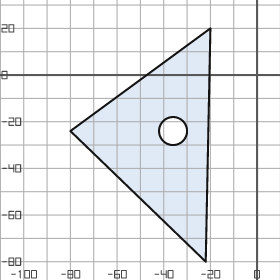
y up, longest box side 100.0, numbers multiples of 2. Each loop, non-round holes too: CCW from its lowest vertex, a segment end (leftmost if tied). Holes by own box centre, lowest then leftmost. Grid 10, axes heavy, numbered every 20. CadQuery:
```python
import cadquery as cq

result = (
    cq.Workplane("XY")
    .moveTo(-22.0, -80.0)
    .lineTo(-20.0, 20.0)
    .lineTo(-80.0, -24.0)
    .close()
    .moveTo(-36.0, -24.0)
    .circle(6.0)
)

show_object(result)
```